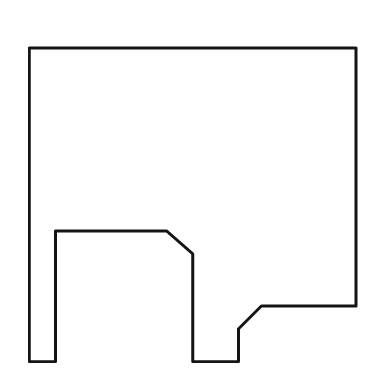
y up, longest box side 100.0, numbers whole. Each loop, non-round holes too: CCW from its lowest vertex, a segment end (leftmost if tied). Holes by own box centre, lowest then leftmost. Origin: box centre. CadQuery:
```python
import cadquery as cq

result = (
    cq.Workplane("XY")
    .moveTo(-50.0, -48.0)
    .lineTo(-42.0, -48.0)
    .lineTo(-42.0, -8.0)
    .lineTo(-8.0, -8.0)
    .lineTo(0.0, -15.0)
    .lineTo(0.0, -48.0)
    .lineTo(14.0, -48.0)
    .lineTo(14.0, -38.0)
    .lineTo(21.0, -31.0)
    .lineTo(50.0, -31.0)
    .lineTo(50.0, 48.0)
    .lineTo(-50.0, 48.0)
    .close()
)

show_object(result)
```